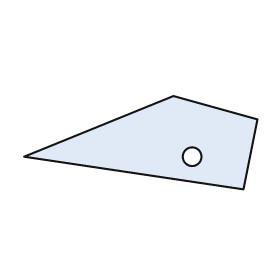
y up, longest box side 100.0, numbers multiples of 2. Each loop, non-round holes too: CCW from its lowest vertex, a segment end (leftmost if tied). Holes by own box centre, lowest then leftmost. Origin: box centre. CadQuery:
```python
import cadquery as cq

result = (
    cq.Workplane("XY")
    .moveTo(44.0, -20.0)
    .lineTo(50.0, 10.0)
    .lineTo(14.0, 20.0)
    .lineTo(-50.0, -6.0)
    .close()
    .moveTo(22.0, -6.0)
    .circle(4.0)
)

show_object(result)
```